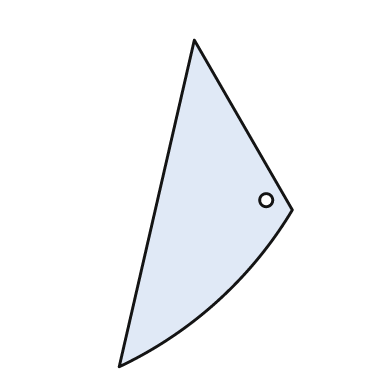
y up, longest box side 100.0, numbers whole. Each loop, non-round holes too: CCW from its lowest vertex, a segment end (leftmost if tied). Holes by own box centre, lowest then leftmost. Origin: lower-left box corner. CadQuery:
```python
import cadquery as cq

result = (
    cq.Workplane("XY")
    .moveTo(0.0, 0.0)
    .threePointArc((30.0, 20.0), (53.0, 48.0))
    .lineTo(23.0, 100.0)
    .close()
    .moveTo(45.0, 51.0)
    .circle(2.0)
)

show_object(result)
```